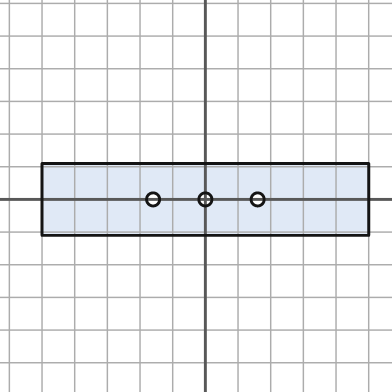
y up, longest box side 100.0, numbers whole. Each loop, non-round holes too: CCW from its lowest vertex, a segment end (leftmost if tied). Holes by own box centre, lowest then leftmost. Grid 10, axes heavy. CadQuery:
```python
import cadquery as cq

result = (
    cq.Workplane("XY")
    .moveTo(-50.0, -11.0)
    .lineTo(50.0, -11.0)
    .lineTo(50.0, 11.0)
    .lineTo(-50.0, 11.0)
    .close()
    .moveTo(-16.0, 0.0)
    .circle(2.0)
    .moveTo(0.0, 0.0)
    .circle(2.0)
    .moveTo(16.0, 0.0)
    .circle(2.0)
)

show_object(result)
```